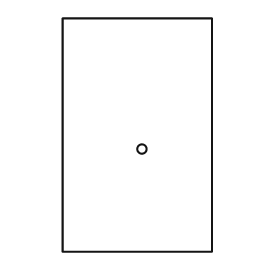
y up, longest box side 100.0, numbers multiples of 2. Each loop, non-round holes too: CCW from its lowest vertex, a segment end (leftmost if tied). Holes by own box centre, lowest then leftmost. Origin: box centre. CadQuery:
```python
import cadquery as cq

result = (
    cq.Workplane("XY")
    .moveTo(-32.0, -50.0)
    .lineTo(32.0, -50.0)
    .lineTo(32.0, 50.0)
    .lineTo(-32.0, 50.0)
    .close()
    .moveTo(2.0, -6.0)
    .circle(2.0)
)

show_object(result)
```